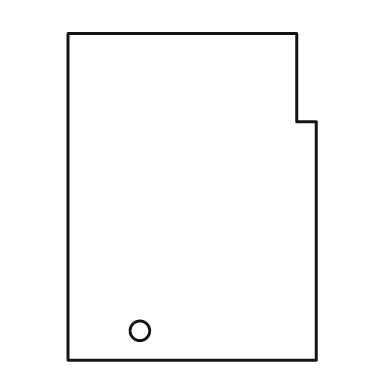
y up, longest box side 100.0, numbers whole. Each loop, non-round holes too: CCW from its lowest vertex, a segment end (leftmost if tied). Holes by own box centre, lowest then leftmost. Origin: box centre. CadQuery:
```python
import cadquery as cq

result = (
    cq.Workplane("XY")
    .moveTo(-38.0, -50.0)
    .lineTo(38.0, -50.0)
    .lineTo(38.0, 23.0)
    .lineTo(32.0, 23.0)
    .lineTo(32.0, 50.0)
    .lineTo(-38.0, 50.0)
    .close()
    .moveTo(-16.0, -41.0)
    .circle(3.0)
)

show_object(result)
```